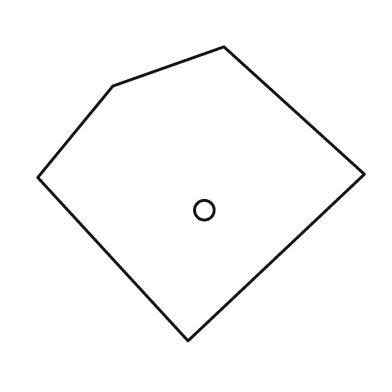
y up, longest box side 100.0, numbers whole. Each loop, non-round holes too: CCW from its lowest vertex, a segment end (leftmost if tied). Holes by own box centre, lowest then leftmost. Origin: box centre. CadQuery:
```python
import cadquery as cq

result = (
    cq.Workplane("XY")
    .moveTo(-4.0, -45.0)
    .lineTo(50.0, 6.0)
    .lineTo(7.0, 45.0)
    .lineTo(-27.0, 33.0)
    .lineTo(-50.0, 5.0)
    .close()
    .moveTo(1.0, -5.0)
    .circle(3.0)
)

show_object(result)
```